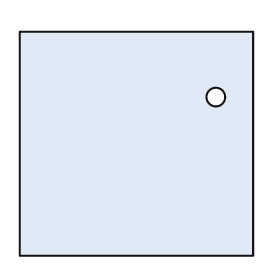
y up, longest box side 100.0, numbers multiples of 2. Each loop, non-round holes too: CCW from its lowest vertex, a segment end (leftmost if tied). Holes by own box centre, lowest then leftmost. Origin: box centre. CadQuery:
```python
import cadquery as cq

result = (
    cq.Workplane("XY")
    .moveTo(-50.0, -48.0)
    .lineTo(50.0, -48.0)
    .lineTo(50.0, 48.0)
    .lineTo(-50.0, 48.0)
    .close()
    .moveTo(34.0, 20.0)
    .circle(4.0)
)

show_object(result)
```